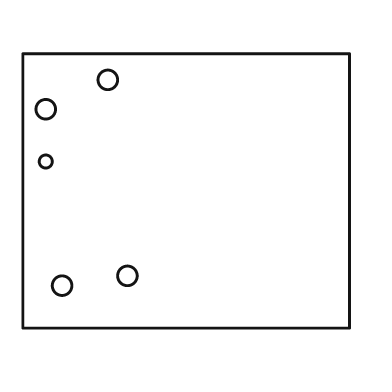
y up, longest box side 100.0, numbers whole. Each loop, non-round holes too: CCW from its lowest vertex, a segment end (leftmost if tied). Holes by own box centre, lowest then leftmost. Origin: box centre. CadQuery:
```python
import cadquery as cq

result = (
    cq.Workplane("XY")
    .moveTo(-50.0, -42.0)
    .lineTo(50.0, -42.0)
    .lineTo(50.0, 42.0)
    .lineTo(-50.0, 42.0)
    .close()
    .moveTo(-38.0, -29.0)
    .circle(3.0)
    .moveTo(-18.0, -26.0)
    .circle(3.0)
    .moveTo(-43.0, 9.0)
    .circle(2.0)
    .moveTo(-43.0, 25.0)
    .circle(3.0)
    .moveTo(-24.0, 34.0)
    .circle(3.0)
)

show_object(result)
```